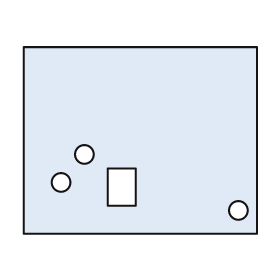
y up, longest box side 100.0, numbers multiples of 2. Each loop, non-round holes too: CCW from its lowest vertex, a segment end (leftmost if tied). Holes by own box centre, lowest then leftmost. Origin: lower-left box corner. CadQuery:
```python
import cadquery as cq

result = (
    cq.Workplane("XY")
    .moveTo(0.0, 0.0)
    .lineTo(100.0, 0.0)
    .lineTo(100.0, 80.0)
    .lineTo(0.0, 80.0)
    .close()
    .moveTo(92.0, 10.0)
    .circle(4.0)
    .moveTo(36.0, 12.0)
    .lineTo(48.0, 12.0)
    .lineTo(48.0, 28.0)
    .lineTo(36.0, 28.0)
    .close()
    .moveTo(16.0, 22.0)
    .circle(4.0)
    .moveTo(26.0, 34.0)
    .circle(4.0)
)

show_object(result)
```